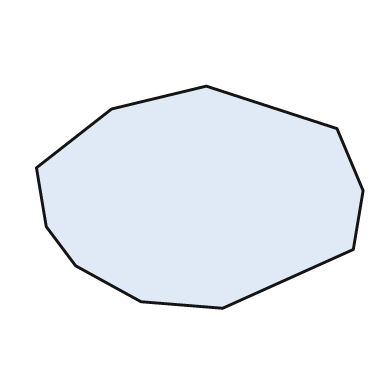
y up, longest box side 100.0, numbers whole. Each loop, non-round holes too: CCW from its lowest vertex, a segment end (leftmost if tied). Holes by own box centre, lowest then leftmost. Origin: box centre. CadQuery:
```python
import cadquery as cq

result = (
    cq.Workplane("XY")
    .moveTo(7.0, -34.0)
    .lineTo(47.0, -16.0)
    .lineTo(50.0, 2.0)
    .lineTo(42.0, 21.0)
    .lineTo(2.0, 34.0)
    .lineTo(-27.0, 27.0)
    .lineTo(-50.0, 9.0)
    .lineTo(-47.0, -9.0)
    .lineTo(-38.0, -21.0)
    .lineTo(-18.0, -32.0)
    .close()
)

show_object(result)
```